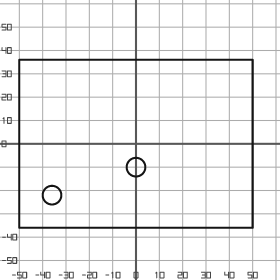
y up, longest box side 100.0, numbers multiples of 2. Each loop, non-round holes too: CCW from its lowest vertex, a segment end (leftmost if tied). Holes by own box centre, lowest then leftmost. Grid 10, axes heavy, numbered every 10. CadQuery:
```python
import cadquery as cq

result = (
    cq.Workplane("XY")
    .moveTo(-50.0, -36.0)
    .lineTo(50.0, -36.0)
    .lineTo(50.0, 36.0)
    .lineTo(-50.0, 36.0)
    .close()
    .moveTo(-36.0, -22.0)
    .circle(4.0)
    .moveTo(0.0, -10.0)
    .circle(4.0)
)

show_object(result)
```